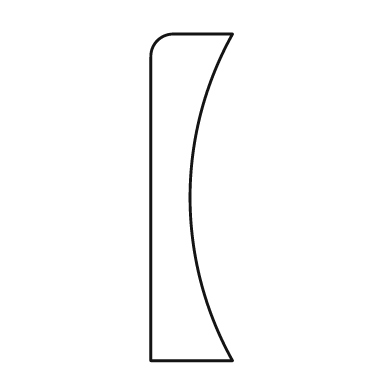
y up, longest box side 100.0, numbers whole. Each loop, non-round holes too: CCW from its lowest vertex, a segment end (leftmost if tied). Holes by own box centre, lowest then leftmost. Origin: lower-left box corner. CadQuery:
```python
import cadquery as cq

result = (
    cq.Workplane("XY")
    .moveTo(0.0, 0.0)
    .lineTo(25.0, 0.0)
    .threePointArc((12.0, 50.0), (25.0, 100.0))
    .lineTo(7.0, 100.0)
    .threePointArc((2.0, 98.0), (0.0, 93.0))
    .close()
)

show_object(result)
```